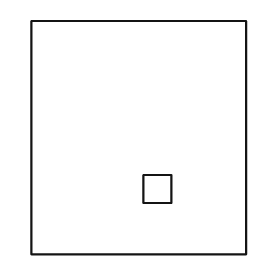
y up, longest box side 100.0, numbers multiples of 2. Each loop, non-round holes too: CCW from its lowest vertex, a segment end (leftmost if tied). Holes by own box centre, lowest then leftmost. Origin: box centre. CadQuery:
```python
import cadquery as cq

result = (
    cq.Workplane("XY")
    .moveTo(-46.0, -50.0)
    .lineTo(46.0, -50.0)
    .lineTo(46.0, 50.0)
    .lineTo(-46.0, 50.0)
    .close()
    .moveTo(2.0, -28.0)
    .lineTo(14.0, -28.0)
    .lineTo(14.0, -16.0)
    .lineTo(2.0, -16.0)
    .close()
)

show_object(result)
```